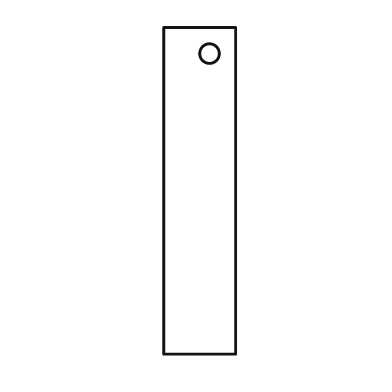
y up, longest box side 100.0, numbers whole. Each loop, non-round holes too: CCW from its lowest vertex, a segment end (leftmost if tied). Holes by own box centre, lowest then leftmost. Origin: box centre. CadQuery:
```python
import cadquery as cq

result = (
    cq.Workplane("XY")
    .moveTo(-11.0, -50.0)
    .lineTo(11.0, -50.0)
    .lineTo(11.0, 50.0)
    .lineTo(-11.0, 50.0)
    .close()
    .moveTo(3.0, 42.0)
    .circle(3.0)
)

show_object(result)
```